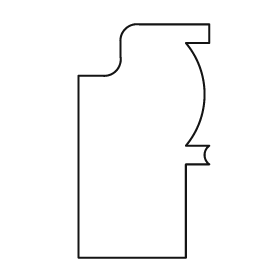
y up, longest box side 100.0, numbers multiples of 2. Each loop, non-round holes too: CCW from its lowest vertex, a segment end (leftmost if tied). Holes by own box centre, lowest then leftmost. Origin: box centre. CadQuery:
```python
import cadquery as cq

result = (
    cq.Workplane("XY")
    .moveTo(-28.0, -50.0)
    .lineTo(18.0, -50.0)
    .lineTo(18.0, -10.0)
    .lineTo(28.0, -10.0)
    .threePointArc((26.0, -6.0), (28.0, -2.0))
    .lineTo(18.0, -2.0)
    .threePointArc((26.0, 20.0), (18.0, 42.0))
    .lineTo(28.0, 42.0)
    .lineTo(28.0, 50.0)
    .lineTo(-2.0, 50.0)
    .threePointArc((-8.0, 48.0), (-10.0, 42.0))
    .lineTo(-10.0, 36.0)
    .threePointArc((-12.0, 30.0), (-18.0, 28.0))
    .lineTo(-28.0, 28.0)
    .close()
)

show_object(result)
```